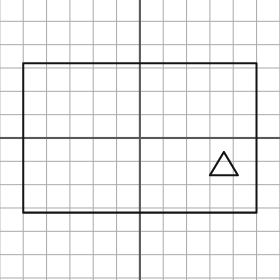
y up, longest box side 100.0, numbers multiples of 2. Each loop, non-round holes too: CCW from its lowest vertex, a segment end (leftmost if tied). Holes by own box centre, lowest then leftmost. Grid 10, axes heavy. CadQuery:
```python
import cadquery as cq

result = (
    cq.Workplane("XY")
    .moveTo(-50.0, -32.0)
    .lineTo(50.0, -32.0)
    .lineTo(50.0, 32.0)
    .lineTo(-50.0, 32.0)
    .close()
    .moveTo(30.0, -16.0)
    .lineTo(42.0, -16.0)
    .lineTo(36.0, -6.0)
    .close()
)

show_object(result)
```